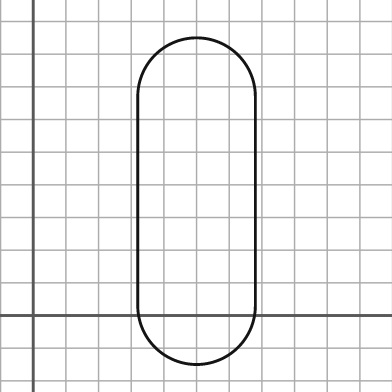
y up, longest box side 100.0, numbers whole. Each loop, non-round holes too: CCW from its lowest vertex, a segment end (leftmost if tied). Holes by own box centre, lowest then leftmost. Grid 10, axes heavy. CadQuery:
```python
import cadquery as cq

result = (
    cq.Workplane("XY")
    .moveTo(32.0, 3.0)
    .threePointArc((50.0, -15.0), (68.0, 3.0))
    .lineTo(68.0, 67.0)
    .threePointArc((50.0, 85.0), (32.0, 67.0))
    .close()
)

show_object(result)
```